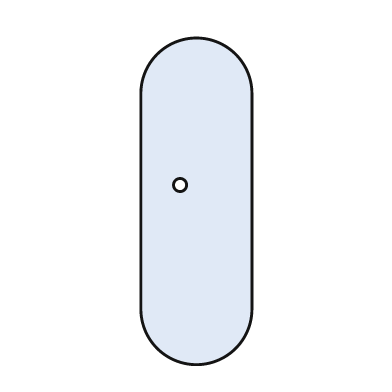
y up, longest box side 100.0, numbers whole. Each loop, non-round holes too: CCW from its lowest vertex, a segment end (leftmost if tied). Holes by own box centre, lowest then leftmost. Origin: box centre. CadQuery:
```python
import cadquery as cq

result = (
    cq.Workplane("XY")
    .moveTo(-17.0, -33.0)
    .threePointArc((0.0, -50.0), (17.0, -33.0))
    .lineTo(17.0, 33.0)
    .threePointArc((0.0, 50.0), (-17.0, 33.0))
    .close()
    .moveTo(-5.0, 5.0)
    .circle(2.0)
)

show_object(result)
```